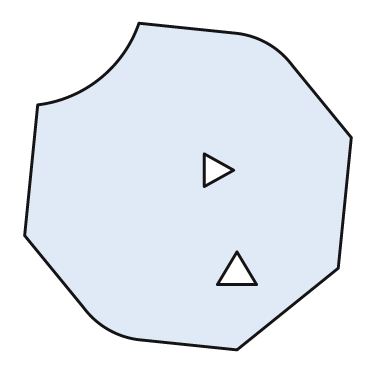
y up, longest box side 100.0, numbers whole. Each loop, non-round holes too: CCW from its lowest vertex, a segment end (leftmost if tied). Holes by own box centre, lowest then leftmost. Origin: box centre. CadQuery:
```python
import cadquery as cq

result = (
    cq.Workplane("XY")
    .moveTo(15.0, -50.0)
    .lineTo(46.0, -25.0)
    .lineTo(50.0, 15.0)
    .lineTo(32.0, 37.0)
    .threePointArc((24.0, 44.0), (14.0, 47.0))
    .lineTo(-15.0, 50.0)
    .threePointArc((-27.0, 33.0), (-46.0, 25.0))
    .lineTo(-50.0, -15.0)
    .lineTo(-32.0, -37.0)
    .threePointArc((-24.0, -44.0), (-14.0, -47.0))
    .close()
    .moveTo(9.0, -30.0)
    .lineTo(21.0, -30.0)
    .lineTo(15.0, -20.0)
    .close()
    .moveTo(5.0, 0.0)
    .lineTo(14.0, 5.0)
    .lineTo(5.0, 10.0)
    .close()
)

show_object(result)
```